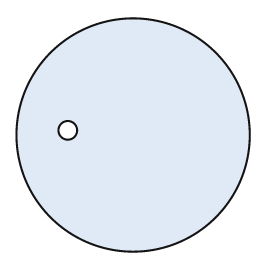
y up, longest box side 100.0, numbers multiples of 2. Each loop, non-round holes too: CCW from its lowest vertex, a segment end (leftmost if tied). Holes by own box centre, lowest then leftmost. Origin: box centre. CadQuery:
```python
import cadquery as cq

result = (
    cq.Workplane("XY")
    .moveTo(0.0, 0.0)
    .circle(50.0)
    .moveTo(-28.0, 2.0)
    .circle(4.0)
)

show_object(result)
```